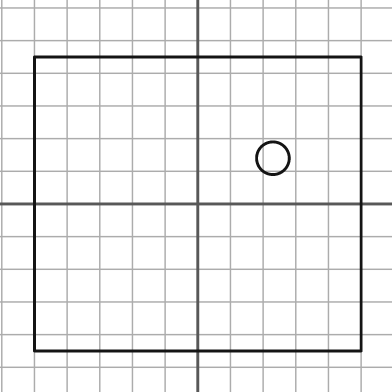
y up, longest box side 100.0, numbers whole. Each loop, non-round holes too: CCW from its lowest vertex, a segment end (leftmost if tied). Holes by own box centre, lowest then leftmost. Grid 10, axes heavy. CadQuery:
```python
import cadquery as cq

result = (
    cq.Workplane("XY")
    .moveTo(-50.0, -45.0)
    .lineTo(50.0, -45.0)
    .lineTo(50.0, 45.0)
    .lineTo(-50.0, 45.0)
    .close()
    .moveTo(23.0, 14.0)
    .circle(5.0)
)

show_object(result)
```